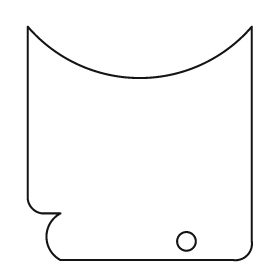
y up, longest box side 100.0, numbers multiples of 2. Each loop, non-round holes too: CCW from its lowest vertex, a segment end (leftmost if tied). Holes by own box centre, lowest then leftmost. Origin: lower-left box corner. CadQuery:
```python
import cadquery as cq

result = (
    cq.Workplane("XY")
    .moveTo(14.0, 0.0)
    .lineTo(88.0, 0.0)
    .threePointArc((94.0, 2.0), (96.0, 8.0))
    .lineTo(96.0, 100.0)
    .threePointArc((48.0, 78.0), (0.0, 100.0))
    .lineTo(0.0, 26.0)
    .threePointArc((2.0, 22.0), (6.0, 20.0))
    .lineTo(14.0, 20.0)
    .threePointArc((8.0, 10.0), (14.0, 0.0))
    .close()
    .moveTo(68.0, 8.0)
    .circle(4.0)
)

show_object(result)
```